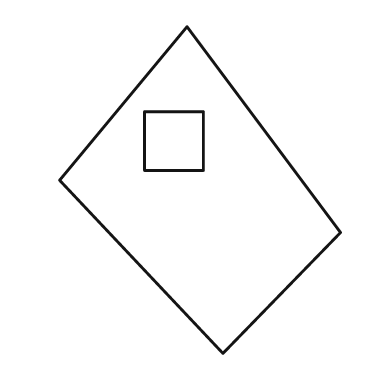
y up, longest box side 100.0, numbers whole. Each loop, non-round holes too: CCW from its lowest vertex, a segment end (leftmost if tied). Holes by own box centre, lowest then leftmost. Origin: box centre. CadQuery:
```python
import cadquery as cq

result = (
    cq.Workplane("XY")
    .moveTo(7.0, -50.0)
    .lineTo(43.0, -13.0)
    .lineTo(-4.0, 50.0)
    .lineTo(-43.0, 3.0)
    .close()
    .moveTo(-17.0, 6.0)
    .lineTo(1.0, 6.0)
    .lineTo(1.0, 24.0)
    .lineTo(-17.0, 24.0)
    .close()
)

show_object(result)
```